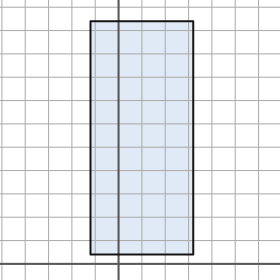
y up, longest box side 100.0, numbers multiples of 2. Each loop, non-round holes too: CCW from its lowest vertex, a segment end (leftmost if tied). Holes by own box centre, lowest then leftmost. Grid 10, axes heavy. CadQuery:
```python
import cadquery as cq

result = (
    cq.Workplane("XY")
    .moveTo(-12.0, 4.0)
    .lineTo(32.0, 4.0)
    .lineTo(32.0, 104.0)
    .lineTo(-12.0, 104.0)
    .close()
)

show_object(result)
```